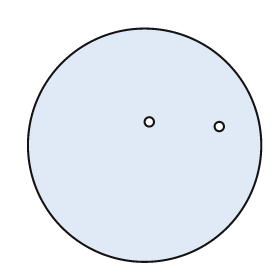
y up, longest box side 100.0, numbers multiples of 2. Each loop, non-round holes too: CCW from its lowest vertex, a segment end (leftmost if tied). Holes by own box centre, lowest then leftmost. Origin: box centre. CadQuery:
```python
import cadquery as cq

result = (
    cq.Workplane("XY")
    .moveTo(0.0, 0.0)
    .circle(50.0)
    .moveTo(32.0, 8.0)
    .circle(2.0)
    .moveTo(2.0, 10.0)
    .circle(2.0)
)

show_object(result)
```